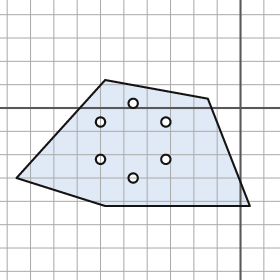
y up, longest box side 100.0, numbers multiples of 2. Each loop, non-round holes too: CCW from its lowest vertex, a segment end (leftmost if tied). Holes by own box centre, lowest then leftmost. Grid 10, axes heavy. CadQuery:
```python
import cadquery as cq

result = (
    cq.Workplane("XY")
    .moveTo(-58.0, -42.0)
    .lineTo(4.0, -42.0)
    .lineTo(-14.0, 4.0)
    .lineTo(-58.0, 12.0)
    .lineTo(-96.0, -30.0)
    .close()
    .moveTo(-46.0, -30.0)
    .circle(2.0)
    .moveTo(-60.0, -22.0)
    .circle(2.0)
    .moveTo(-32.0, -22.0)
    .circle(2.0)
    .moveTo(-60.0, -6.0)
    .circle(2.0)
    .moveTo(-32.0, -6.0)
    .circle(2.0)
    .moveTo(-46.0, 2.0)
    .circle(2.0)
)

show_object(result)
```